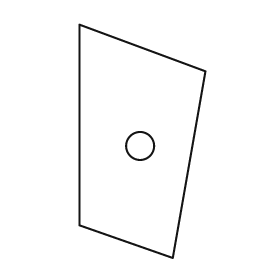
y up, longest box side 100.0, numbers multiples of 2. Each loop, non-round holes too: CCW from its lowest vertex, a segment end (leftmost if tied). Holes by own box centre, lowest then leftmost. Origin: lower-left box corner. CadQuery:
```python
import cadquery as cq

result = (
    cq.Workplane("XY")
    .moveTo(40.0, 0.0)
    .lineTo(54.0, 80.0)
    .lineTo(0.0, 100.0)
    .lineTo(0.0, 14.0)
    .close()
    .moveTo(26.0, 48.0)
    .circle(6.0)
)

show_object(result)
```